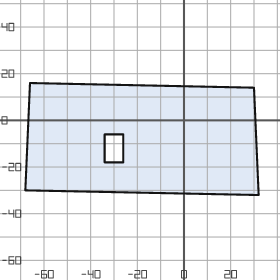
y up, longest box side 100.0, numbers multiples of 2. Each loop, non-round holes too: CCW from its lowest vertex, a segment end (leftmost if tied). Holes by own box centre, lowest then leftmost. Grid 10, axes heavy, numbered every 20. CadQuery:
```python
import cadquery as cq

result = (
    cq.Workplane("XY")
    .moveTo(32.0, -32.0)
    .lineTo(30.0, 14.0)
    .lineTo(-66.0, 16.0)
    .lineTo(-68.0, -30.0)
    .close()
    .moveTo(-34.0, -18.0)
    .lineTo(-26.0, -18.0)
    .lineTo(-26.0, -6.0)
    .lineTo(-34.0, -6.0)
    .close()
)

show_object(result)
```